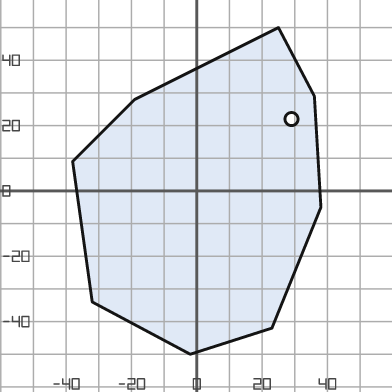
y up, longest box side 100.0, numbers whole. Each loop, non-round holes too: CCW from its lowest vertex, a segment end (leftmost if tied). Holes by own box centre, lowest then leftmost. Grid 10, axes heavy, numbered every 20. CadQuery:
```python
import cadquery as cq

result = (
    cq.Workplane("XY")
    .moveTo(-2.0, -50.0)
    .lineTo(23.0, -42.0)
    .lineTo(38.0, -5.0)
    .lineTo(36.0, 29.0)
    .lineTo(25.0, 50.0)
    .lineTo(-19.0, 28.0)
    .lineTo(-38.0, 9.0)
    .lineTo(-32.0, -34.0)
    .close()
    .moveTo(29.0, 22.0)
    .circle(2.0)
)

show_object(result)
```